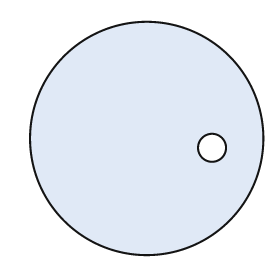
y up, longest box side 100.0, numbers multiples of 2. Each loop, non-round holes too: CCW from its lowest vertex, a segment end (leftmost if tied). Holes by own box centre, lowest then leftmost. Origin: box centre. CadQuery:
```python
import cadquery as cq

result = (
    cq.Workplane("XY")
    .moveTo(0.0, 0.0)
    .circle(50.0)
    .moveTo(28.0, -4.0)
    .circle(6.0)
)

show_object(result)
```